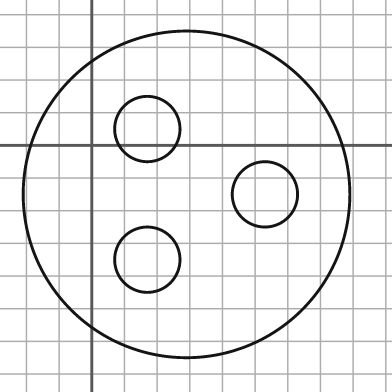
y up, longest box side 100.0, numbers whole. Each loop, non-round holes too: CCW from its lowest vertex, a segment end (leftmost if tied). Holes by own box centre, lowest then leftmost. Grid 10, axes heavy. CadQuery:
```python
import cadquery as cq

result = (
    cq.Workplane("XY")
    .moveTo(29.0, -15.0)
    .circle(50.0)
    .moveTo(17.0, -35.0)
    .circle(10.0)
    .moveTo(53.0, -15.0)
    .circle(10.0)
    .moveTo(17.0, 5.0)
    .circle(10.0)
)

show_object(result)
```